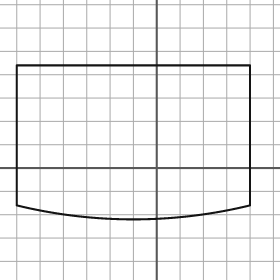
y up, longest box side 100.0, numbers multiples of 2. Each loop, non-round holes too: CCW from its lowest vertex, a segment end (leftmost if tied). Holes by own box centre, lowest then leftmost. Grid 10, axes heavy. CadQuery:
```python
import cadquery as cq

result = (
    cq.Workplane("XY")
    .moveTo(-60.0, -16.0)
    .threePointArc((-10.0, -22.0), (40.0, -16.0))
    .lineTo(40.0, 44.0)
    .lineTo(-60.0, 44.0)
    .close()
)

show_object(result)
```